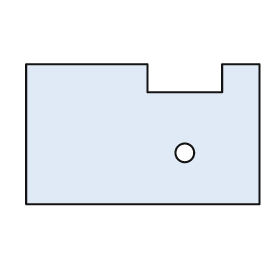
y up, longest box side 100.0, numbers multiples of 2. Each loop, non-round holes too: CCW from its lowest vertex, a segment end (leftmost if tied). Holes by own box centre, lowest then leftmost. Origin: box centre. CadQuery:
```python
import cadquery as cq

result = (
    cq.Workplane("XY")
    .moveTo(-50.0, -30.0)
    .lineTo(50.0, -30.0)
    .lineTo(50.0, 30.0)
    .lineTo(34.0, 30.0)
    .lineTo(34.0, 18.0)
    .lineTo(2.0, 18.0)
    .lineTo(2.0, 30.0)
    .lineTo(-50.0, 30.0)
    .close()
    .moveTo(18.0, -8.0)
    .circle(4.0)
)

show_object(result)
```